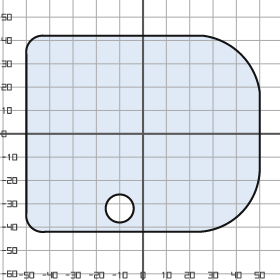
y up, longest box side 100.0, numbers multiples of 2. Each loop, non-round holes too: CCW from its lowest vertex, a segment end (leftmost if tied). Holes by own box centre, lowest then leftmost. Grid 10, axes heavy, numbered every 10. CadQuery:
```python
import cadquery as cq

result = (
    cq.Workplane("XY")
    .moveTo(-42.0, -42.0)
    .lineTo(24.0, -42.0)
    .threePointArc((42.0, -34.0), (50.0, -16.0))
    .lineTo(50.0, 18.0)
    .threePointArc((42.0, 34.0), (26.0, 42.0))
    .lineTo(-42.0, 42.0)
    .threePointArc((-48.0, 40.0), (-50.0, 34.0))
    .lineTo(-50.0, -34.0)
    .threePointArc((-48.0, -40.0), (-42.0, -42.0))
    .close()
    .moveTo(-10.0, -32.0)
    .circle(6.0)
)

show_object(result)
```